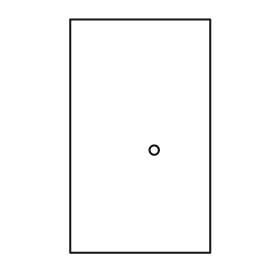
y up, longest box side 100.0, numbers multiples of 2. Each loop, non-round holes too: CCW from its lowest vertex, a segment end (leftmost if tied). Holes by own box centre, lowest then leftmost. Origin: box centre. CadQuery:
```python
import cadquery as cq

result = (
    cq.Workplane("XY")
    .moveTo(-30.0, -50.0)
    .lineTo(30.0, -50.0)
    .lineTo(30.0, 50.0)
    .lineTo(-30.0, 50.0)
    .close()
    .moveTo(6.0, -6.0)
    .circle(2.0)
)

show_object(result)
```